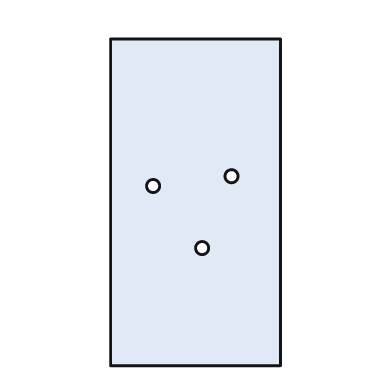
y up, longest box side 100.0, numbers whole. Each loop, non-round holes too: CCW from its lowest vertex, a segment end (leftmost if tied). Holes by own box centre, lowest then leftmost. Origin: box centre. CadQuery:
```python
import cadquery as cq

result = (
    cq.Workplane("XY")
    .moveTo(-26.0, -50.0)
    .lineTo(26.0, -50.0)
    .lineTo(26.0, 50.0)
    .lineTo(-26.0, 50.0)
    .close()
    .moveTo(2.0, -14.0)
    .circle(2.0)
    .moveTo(-13.0, 5.0)
    .circle(2.0)
    .moveTo(11.0, 8.0)
    .circle(2.0)
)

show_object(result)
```